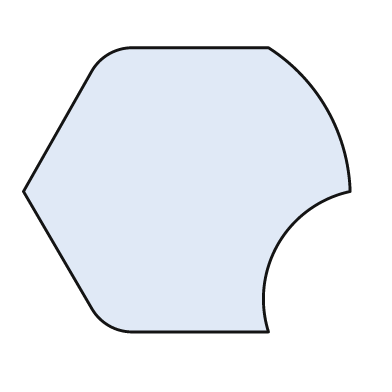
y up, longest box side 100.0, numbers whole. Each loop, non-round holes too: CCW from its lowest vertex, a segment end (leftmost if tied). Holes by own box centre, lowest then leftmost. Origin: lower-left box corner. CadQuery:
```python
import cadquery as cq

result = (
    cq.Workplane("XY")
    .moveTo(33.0, 0.0)
    .lineTo(75.0, 0.0)
    .threePointArc((78.0, 27.0), (100.0, 43.0))
    .threePointArc((93.0, 68.0), (75.0, 87.0))
    .lineTo(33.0, 87.0)
    .threePointArc((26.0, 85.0), (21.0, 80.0))
    .lineTo(0.0, 43.0)
    .lineTo(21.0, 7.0)
    .threePointArc((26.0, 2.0), (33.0, 0.0))
    .close()
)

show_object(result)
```